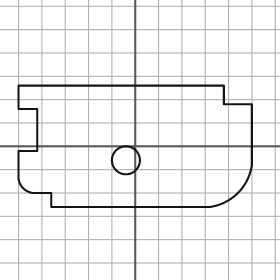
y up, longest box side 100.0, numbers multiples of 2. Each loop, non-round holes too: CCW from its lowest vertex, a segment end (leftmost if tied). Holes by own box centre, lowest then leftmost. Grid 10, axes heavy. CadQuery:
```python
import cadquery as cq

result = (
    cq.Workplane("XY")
    .moveTo(-36.0, -26.0)
    .lineTo(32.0, -26.0)
    .threePointArc((44.0, -20.0), (50.0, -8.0))
    .lineTo(50.0, 18.0)
    .lineTo(38.0, 18.0)
    .lineTo(38.0, 26.0)
    .lineTo(-50.0, 26.0)
    .lineTo(-50.0, 16.0)
    .lineTo(-42.0, 16.0)
    .lineTo(-42.0, -2.0)
    .lineTo(-50.0, -2.0)
    .lineTo(-50.0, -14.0)
    .threePointArc((-48.0, -18.0), (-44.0, -20.0))
    .lineTo(-36.0, -20.0)
    .close()
    .moveTo(-4.0, -6.0)
    .circle(6.0)
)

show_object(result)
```